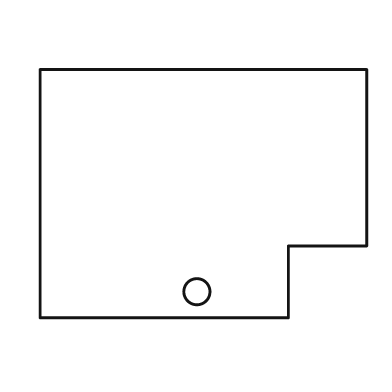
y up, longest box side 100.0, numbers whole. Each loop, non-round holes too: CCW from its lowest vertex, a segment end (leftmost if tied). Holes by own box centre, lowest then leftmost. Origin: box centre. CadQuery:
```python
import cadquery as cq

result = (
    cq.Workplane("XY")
    .moveTo(-50.0, -38.0)
    .lineTo(26.0, -38.0)
    .lineTo(26.0, -16.0)
    .lineTo(50.0, -16.0)
    .lineTo(50.0, 38.0)
    .lineTo(-50.0, 38.0)
    .close()
    .moveTo(-2.0, -30.0)
    .circle(4.0)
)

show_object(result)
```